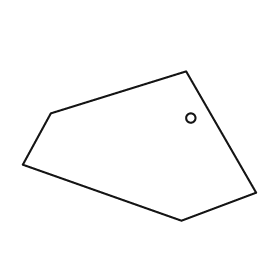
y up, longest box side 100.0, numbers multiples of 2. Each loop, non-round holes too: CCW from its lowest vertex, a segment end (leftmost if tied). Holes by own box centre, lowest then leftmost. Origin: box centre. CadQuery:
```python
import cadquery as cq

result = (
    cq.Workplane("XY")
    .moveTo(18.0, -32.0)
    .lineTo(50.0, -20.0)
    .lineTo(20.0, 32.0)
    .lineTo(-38.0, 14.0)
    .lineTo(-50.0, -8.0)
    .close()
    .moveTo(22.0, 12.0)
    .circle(2.0)
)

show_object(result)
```